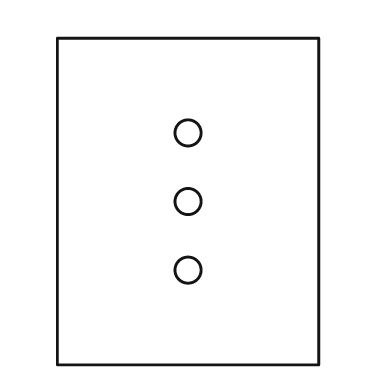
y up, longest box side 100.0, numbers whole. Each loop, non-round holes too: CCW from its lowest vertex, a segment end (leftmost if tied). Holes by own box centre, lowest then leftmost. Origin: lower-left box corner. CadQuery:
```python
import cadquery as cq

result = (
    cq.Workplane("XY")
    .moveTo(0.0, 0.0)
    .lineTo(80.0, 0.0)
    .lineTo(80.0, 100.0)
    .lineTo(0.0, 100.0)
    .close()
    .moveTo(40.0, 29.0)
    .circle(4.0)
    .moveTo(40.0, 50.0)
    .circle(4.0)
    .moveTo(40.0, 71.0)
    .circle(4.0)
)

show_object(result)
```